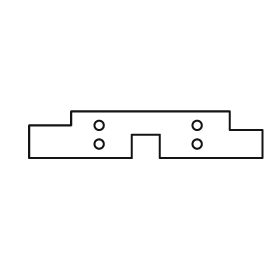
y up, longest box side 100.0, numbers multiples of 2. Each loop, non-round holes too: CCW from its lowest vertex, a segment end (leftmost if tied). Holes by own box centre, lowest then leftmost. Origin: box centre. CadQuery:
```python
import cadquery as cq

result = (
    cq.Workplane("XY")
    .moveTo(-50.0, -10.0)
    .lineTo(-6.0, -10.0)
    .lineTo(-6.0, 0.0)
    .lineTo(6.0, 0.0)
    .lineTo(6.0, -10.0)
    .lineTo(50.0, -10.0)
    .lineTo(50.0, 2.0)
    .lineTo(36.0, 2.0)
    .lineTo(36.0, 10.0)
    .lineTo(-32.0, 10.0)
    .lineTo(-32.0, 4.0)
    .lineTo(-50.0, 4.0)
    .close()
    .moveTo(-20.0, -4.0)
    .circle(2.0)
    .moveTo(22.0, -4.0)
    .circle(2.0)
    .moveTo(-20.0, 4.0)
    .circle(2.0)
    .moveTo(22.0, 4.0)
    .circle(2.0)
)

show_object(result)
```